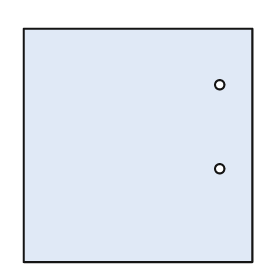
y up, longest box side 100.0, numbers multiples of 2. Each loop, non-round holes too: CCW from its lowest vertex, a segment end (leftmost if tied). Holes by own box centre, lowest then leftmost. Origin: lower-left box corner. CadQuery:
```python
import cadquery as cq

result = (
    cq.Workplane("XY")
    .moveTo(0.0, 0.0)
    .lineTo(98.0, 0.0)
    .lineTo(98.0, 100.0)
    .lineTo(0.0, 100.0)
    .close()
    .moveTo(84.0, 40.0)
    .circle(2.0)
    .moveTo(84.0, 76.0)
    .circle(2.0)
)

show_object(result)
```